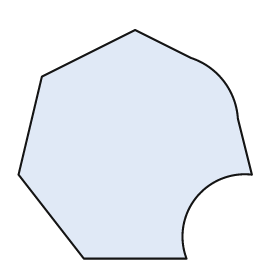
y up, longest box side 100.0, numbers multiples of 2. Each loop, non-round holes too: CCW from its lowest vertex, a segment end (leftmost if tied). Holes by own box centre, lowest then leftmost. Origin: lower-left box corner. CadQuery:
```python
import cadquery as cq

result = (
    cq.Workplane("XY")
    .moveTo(28.0, 0.0)
    .lineTo(72.0, 0.0)
    .threePointArc((76.0, 26.0), (100.0, 36.0))
    .lineTo(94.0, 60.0)
    .threePointArc((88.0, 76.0), (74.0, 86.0))
    .lineTo(50.0, 98.0)
    .lineTo(10.0, 78.0)
    .lineTo(0.0, 36.0)
    .close()
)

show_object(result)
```